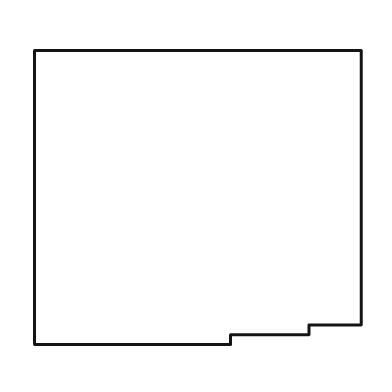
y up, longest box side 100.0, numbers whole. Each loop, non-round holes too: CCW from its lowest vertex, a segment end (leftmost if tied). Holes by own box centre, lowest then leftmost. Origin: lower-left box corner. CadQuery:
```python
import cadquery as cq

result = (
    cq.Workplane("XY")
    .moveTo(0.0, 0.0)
    .lineTo(60.0, 0.0)
    .lineTo(60.0, 3.0)
    .lineTo(84.0, 3.0)
    .lineTo(84.0, 6.0)
    .lineTo(100.0, 6.0)
    .lineTo(100.0, 90.0)
    .lineTo(0.0, 90.0)
    .close()
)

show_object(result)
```